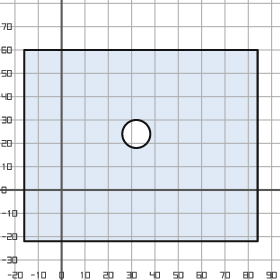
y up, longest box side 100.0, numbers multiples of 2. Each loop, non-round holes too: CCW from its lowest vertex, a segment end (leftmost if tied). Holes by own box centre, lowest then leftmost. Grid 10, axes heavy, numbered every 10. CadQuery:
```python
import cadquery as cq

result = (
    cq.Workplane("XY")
    .moveTo(-16.0, -22.0)
    .lineTo(84.0, -22.0)
    .lineTo(84.0, 60.0)
    .lineTo(-16.0, 60.0)
    .close()
    .moveTo(32.0, 24.0)
    .circle(6.0)
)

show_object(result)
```